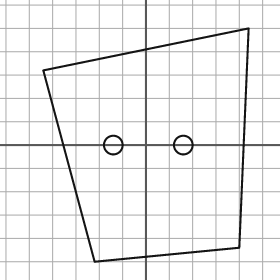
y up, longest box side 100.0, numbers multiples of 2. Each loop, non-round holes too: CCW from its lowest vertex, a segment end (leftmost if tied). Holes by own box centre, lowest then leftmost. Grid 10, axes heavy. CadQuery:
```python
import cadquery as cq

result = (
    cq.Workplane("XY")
    .moveTo(-22.0, -50.0)
    .lineTo(40.0, -44.0)
    .lineTo(44.0, 50.0)
    .lineTo(-44.0, 32.0)
    .close()
    .moveTo(-14.0, 0.0)
    .circle(4.0)
    .moveTo(16.0, 0.0)
    .circle(4.0)
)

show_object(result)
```